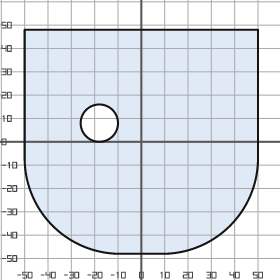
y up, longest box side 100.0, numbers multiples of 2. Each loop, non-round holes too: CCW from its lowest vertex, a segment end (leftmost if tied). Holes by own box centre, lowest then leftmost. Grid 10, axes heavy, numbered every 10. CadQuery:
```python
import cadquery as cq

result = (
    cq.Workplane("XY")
    .moveTo(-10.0, -48.0)
    .lineTo(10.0, -48.0)
    .threePointArc((38.0, -36.0), (50.0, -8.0))
    .lineTo(50.0, 48.0)
    .lineTo(-50.0, 48.0)
    .lineTo(-50.0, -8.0)
    .threePointArc((-38.0, -36.0), (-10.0, -48.0))
    .close()
    .moveTo(-18.0, 8.0)
    .circle(8.0)
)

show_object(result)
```